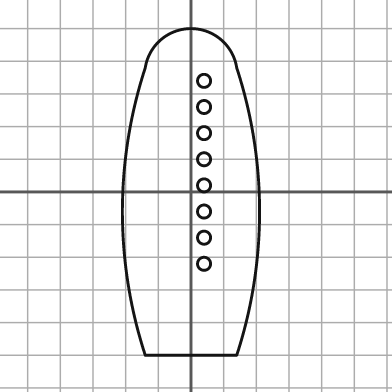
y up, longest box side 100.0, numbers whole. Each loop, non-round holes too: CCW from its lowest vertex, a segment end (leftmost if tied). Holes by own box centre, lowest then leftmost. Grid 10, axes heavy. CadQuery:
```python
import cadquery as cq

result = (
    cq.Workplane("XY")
    .moveTo(-14.0, -50.0)
    .lineTo(14.0, -50.0)
    .threePointArc((21.0, -6.0), (14.0, 38.0))
    .threePointArc((0.0, 50.0), (-14.0, 38.0))
    .threePointArc((-21.0, -6.0), (-14.0, -50.0))
    .close()
    .moveTo(4.0, -22.0)
    .circle(2.0)
    .moveTo(4.0, -14.0)
    .circle(2.0)
    .moveTo(4.0, -6.0)
    .circle(2.0)
    .moveTo(4.0, 2.0)
    .circle(2.0)
    .moveTo(4.0, 10.0)
    .circle(2.0)
    .moveTo(4.0, 18.0)
    .circle(2.0)
    .moveTo(4.0, 26.0)
    .circle(2.0)
    .moveTo(4.0, 34.0)
    .circle(2.0)
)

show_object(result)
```